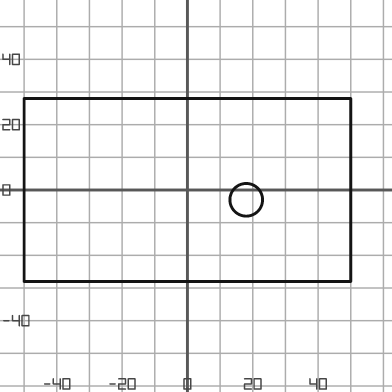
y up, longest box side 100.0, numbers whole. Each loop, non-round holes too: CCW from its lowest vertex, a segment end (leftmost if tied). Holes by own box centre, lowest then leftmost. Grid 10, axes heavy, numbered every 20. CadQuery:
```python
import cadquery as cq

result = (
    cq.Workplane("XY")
    .moveTo(-50.0, -28.0)
    .lineTo(50.0, -28.0)
    .lineTo(50.0, 28.0)
    .lineTo(-50.0, 28.0)
    .close()
    .moveTo(18.0, -3.0)
    .circle(5.0)
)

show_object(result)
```